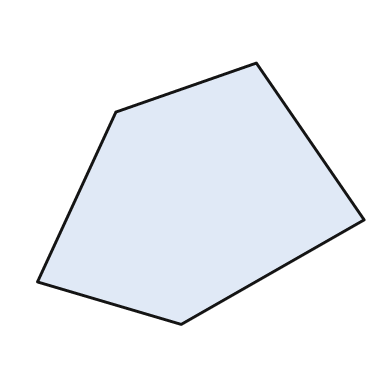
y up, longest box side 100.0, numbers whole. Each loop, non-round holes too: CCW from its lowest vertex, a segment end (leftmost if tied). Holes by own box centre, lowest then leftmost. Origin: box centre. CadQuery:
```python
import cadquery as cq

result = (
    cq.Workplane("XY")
    .moveTo(-6.0, -40.0)
    .lineTo(50.0, -8.0)
    .lineTo(17.0, 40.0)
    .lineTo(-26.0, 25.0)
    .lineTo(-50.0, -27.0)
    .close()
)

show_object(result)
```